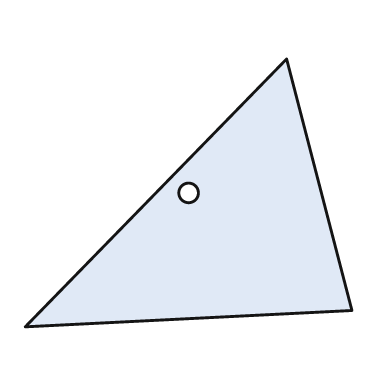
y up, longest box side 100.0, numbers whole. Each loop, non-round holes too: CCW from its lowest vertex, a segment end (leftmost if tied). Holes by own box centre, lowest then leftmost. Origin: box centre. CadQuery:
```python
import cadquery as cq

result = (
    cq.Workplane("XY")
    .moveTo(-50.0, -41.0)
    .lineTo(50.0, -36.0)
    .lineTo(30.0, 41.0)
    .close()
    .moveTo(0.0, 0.0)
    .circle(3.0)
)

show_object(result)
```